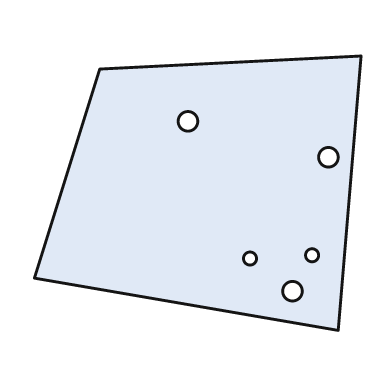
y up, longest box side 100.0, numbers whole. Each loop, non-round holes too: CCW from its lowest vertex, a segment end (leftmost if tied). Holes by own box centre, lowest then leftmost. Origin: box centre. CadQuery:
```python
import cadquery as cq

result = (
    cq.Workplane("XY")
    .moveTo(43.0, -42.0)
    .lineTo(50.0, 42.0)
    .lineTo(-30.0, 38.0)
    .lineTo(-50.0, -26.0)
    .close()
    .moveTo(29.0, -30.0)
    .circle(3.0)
    .moveTo(16.0, -20.0)
    .circle(2.0)
    .moveTo(35.0, -19.0)
    .circle(2.0)
    .moveTo(40.0, 11.0)
    .circle(3.0)
    .moveTo(-3.0, 22.0)
    .circle(3.0)
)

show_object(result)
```